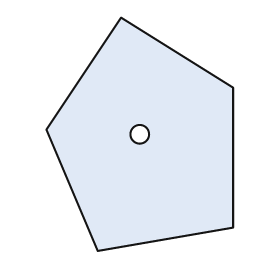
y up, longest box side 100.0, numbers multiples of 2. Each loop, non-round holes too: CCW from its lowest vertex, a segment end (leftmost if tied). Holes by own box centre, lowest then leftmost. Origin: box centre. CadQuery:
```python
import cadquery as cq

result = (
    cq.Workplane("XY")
    .moveTo(-18.0, -50.0)
    .lineTo(40.0, -40.0)
    .lineTo(40.0, 20.0)
    .lineTo(-8.0, 50.0)
    .lineTo(-40.0, 2.0)
    .close()
    .moveTo(0.0, 0.0)
    .circle(4.0)
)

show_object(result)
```